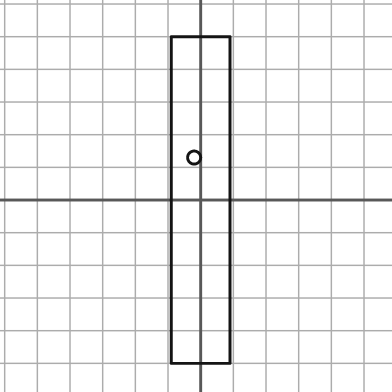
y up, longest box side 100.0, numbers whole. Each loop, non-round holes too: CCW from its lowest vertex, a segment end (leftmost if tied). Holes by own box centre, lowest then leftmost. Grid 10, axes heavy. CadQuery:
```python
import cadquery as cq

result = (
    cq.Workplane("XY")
    .moveTo(-9.0, -50.0)
    .lineTo(9.0, -50.0)
    .lineTo(9.0, 50.0)
    .lineTo(-9.0, 50.0)
    .close()
    .moveTo(-2.0, 13.0)
    .circle(2.0)
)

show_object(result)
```